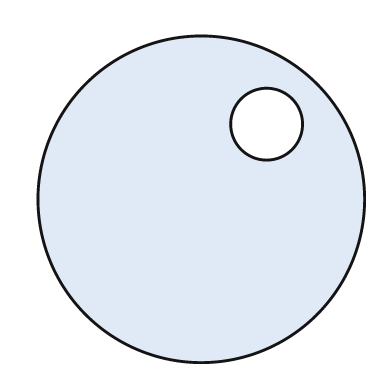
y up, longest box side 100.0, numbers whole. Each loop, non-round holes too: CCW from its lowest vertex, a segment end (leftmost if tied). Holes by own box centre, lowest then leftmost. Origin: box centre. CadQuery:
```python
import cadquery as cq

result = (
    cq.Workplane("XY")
    .moveTo(0.0, 0.0)
    .circle(50.0)
    .moveTo(20.0, 23.0)
    .circle(11.0)
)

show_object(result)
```